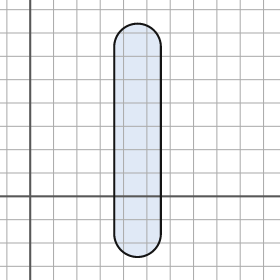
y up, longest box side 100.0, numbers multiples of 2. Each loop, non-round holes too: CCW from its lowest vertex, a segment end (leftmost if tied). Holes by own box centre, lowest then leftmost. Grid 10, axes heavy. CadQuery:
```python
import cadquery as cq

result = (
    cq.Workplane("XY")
    .moveTo(36.0, -16.0)
    .threePointArc((46.0, -26.0), (56.0, -16.0))
    .lineTo(56.0, 64.0)
    .threePointArc((46.0, 74.0), (36.0, 64.0))
    .close()
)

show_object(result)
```